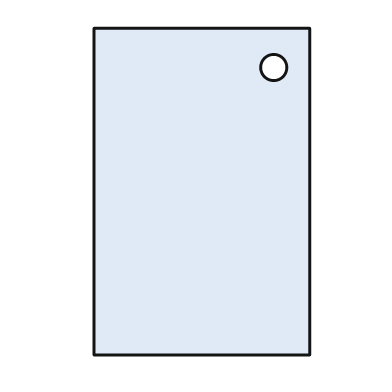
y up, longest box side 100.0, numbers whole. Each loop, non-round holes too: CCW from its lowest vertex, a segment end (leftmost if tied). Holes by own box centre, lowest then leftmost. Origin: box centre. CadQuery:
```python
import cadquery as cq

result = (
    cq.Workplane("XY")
    .moveTo(-33.0, -50.0)
    .lineTo(33.0, -50.0)
    .lineTo(33.0, 50.0)
    .lineTo(-33.0, 50.0)
    .close()
    .moveTo(22.0, 38.0)
    .circle(4.0)
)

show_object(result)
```